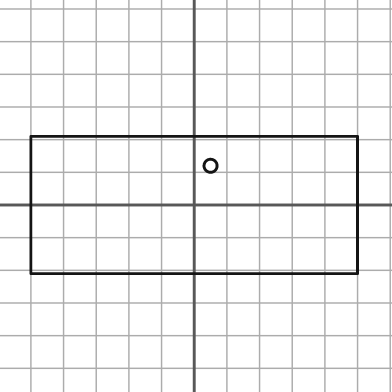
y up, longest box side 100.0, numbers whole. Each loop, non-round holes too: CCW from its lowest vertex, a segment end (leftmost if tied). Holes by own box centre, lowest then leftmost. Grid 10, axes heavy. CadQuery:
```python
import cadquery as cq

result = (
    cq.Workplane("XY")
    .moveTo(-50.0, -21.0)
    .lineTo(50.0, -21.0)
    .lineTo(50.0, 21.0)
    .lineTo(-50.0, 21.0)
    .close()
    .moveTo(5.0, 12.0)
    .circle(2.0)
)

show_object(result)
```